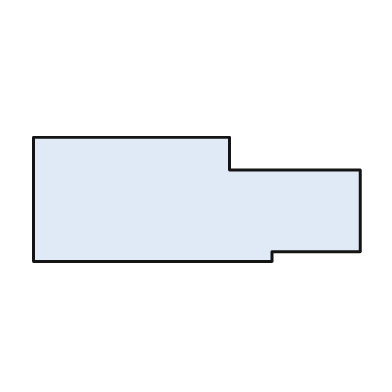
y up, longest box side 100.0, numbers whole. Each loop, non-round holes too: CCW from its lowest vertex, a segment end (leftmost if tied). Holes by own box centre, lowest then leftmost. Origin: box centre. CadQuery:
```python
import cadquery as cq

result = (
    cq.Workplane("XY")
    .moveTo(-50.0, -19.0)
    .lineTo(23.0, -19.0)
    .lineTo(23.0, -16.0)
    .lineTo(50.0, -16.0)
    .lineTo(50.0, 9.0)
    .lineTo(10.0, 9.0)
    .lineTo(10.0, 19.0)
    .lineTo(-50.0, 19.0)
    .close()
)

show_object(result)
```